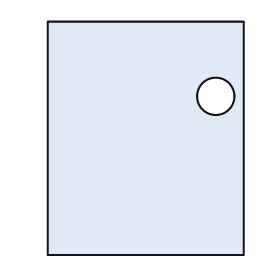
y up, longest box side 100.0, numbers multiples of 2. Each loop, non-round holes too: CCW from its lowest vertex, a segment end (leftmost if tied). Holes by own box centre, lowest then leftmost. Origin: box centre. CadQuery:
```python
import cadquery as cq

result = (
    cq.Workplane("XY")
    .moveTo(-42.0, -50.0)
    .lineTo(42.0, -50.0)
    .lineTo(42.0, 50.0)
    .lineTo(-42.0, 50.0)
    .close()
    .moveTo(30.0, 18.0)
    .circle(8.0)
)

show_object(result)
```